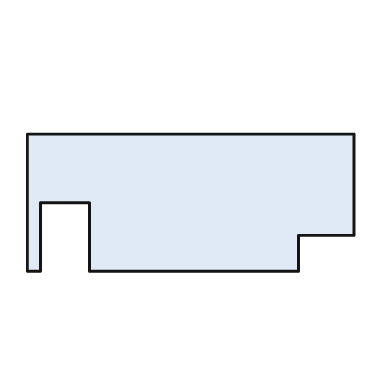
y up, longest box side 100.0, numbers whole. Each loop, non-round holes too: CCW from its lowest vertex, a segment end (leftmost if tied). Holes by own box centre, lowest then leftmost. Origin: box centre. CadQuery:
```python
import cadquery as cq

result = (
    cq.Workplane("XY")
    .moveTo(-50.0, -21.0)
    .lineTo(-46.0, -21.0)
    .lineTo(-46.0, 0.0)
    .lineTo(-31.0, 0.0)
    .lineTo(-31.0, -21.0)
    .lineTo(33.0, -21.0)
    .lineTo(33.0, -10.0)
    .lineTo(50.0, -10.0)
    .lineTo(50.0, 21.0)
    .lineTo(-50.0, 21.0)
    .close()
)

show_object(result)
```